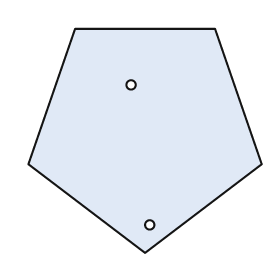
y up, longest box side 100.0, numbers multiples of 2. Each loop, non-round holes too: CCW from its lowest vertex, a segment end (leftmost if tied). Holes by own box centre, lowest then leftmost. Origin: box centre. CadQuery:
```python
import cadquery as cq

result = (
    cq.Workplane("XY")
    .moveTo(0.0, -48.0)
    .lineTo(50.0, -10.0)
    .lineTo(30.0, 48.0)
    .lineTo(-30.0, 48.0)
    .lineTo(-50.0, -10.0)
    .close()
    .moveTo(2.0, -36.0)
    .circle(2.0)
    .moveTo(-6.0, 24.0)
    .circle(2.0)
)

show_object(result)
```